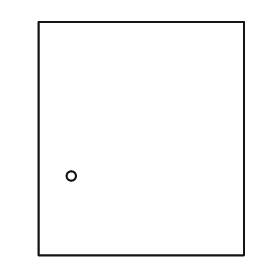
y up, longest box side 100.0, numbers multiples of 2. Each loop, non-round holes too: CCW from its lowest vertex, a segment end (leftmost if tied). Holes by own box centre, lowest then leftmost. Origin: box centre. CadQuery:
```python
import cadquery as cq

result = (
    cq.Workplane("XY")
    .moveTo(-44.0, -50.0)
    .lineTo(44.0, -50.0)
    .lineTo(44.0, 50.0)
    .lineTo(-44.0, 50.0)
    .close()
    .moveTo(-30.0, -16.0)
    .circle(2.0)
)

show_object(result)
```